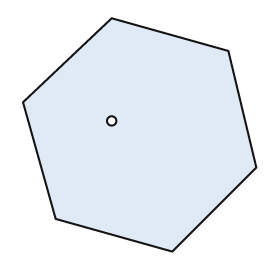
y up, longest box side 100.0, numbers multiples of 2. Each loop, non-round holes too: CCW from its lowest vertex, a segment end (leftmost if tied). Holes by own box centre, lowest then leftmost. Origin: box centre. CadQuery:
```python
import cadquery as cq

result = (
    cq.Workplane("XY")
    .moveTo(14.0, -50.0)
    .lineTo(50.0, -14.0)
    .lineTo(38.0, 36.0)
    .lineTo(-12.0, 50.0)
    .lineTo(-50.0, 14.0)
    .lineTo(-36.0, -36.0)
    .close()
    .moveTo(-12.0, 6.0)
    .circle(2.0)
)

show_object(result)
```